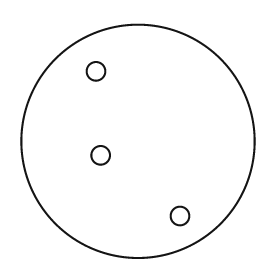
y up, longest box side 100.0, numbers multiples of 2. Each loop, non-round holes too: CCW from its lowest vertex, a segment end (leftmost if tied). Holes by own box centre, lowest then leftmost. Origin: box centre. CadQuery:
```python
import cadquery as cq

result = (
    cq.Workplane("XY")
    .moveTo(0.0, 0.0)
    .circle(50.0)
    .moveTo(18.0, -32.0)
    .circle(4.0)
    .moveTo(-16.0, -6.0)
    .circle(4.0)
    .moveTo(-18.0, 30.0)
    .circle(4.0)
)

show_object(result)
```